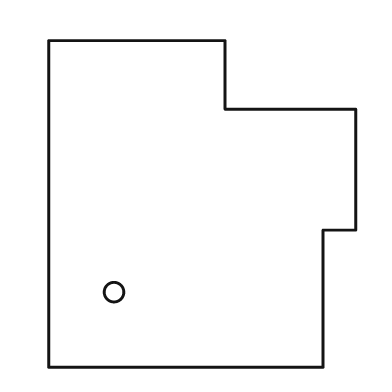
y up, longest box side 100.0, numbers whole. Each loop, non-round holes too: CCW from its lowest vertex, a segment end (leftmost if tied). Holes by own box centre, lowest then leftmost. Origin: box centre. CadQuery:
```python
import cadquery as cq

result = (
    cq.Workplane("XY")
    .moveTo(-47.0, -50.0)
    .lineTo(37.0, -50.0)
    .lineTo(37.0, -8.0)
    .lineTo(47.0, -8.0)
    .lineTo(47.0, 29.0)
    .lineTo(7.0, 29.0)
    .lineTo(7.0, 50.0)
    .lineTo(-47.0, 50.0)
    .close()
    .moveTo(-27.0, -27.0)
    .circle(3.0)
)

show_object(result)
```